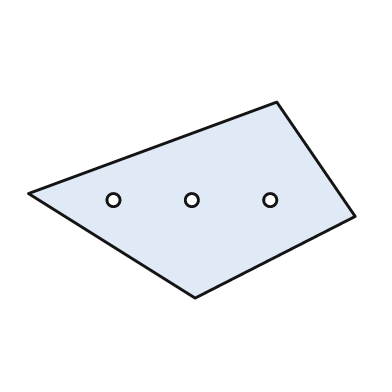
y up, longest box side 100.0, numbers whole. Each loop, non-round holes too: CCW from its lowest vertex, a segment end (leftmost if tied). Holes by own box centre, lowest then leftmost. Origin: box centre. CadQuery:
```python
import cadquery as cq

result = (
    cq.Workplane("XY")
    .moveTo(1.0, -30.0)
    .lineTo(50.0, -5.0)
    .lineTo(26.0, 30.0)
    .lineTo(-50.0, 2.0)
    .close()
    .moveTo(-24.0, 0.0)
    .circle(2.0)
    .moveTo(0.0, 0.0)
    .circle(2.0)
    .moveTo(24.0, 0.0)
    .circle(2.0)
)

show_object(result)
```